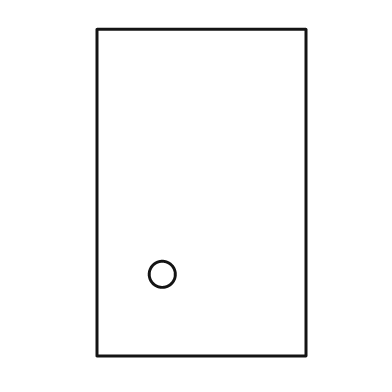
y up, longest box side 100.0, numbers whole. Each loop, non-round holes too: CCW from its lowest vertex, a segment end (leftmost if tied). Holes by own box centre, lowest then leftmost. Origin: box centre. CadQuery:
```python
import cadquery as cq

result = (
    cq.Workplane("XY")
    .moveTo(-32.0, -50.0)
    .lineTo(32.0, -50.0)
    .lineTo(32.0, 50.0)
    .lineTo(-32.0, 50.0)
    .close()
    .moveTo(-12.0, -25.0)
    .circle(4.0)
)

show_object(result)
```